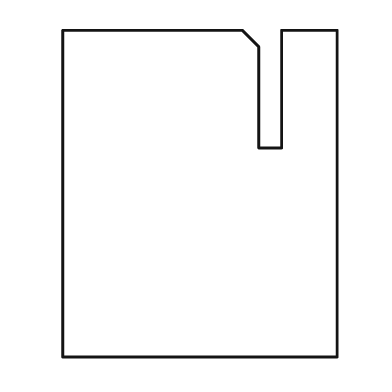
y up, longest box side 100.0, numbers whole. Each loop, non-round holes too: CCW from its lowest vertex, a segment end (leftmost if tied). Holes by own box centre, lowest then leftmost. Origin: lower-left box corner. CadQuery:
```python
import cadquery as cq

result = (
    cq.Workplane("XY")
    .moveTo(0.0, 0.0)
    .lineTo(84.0, 0.0)
    .lineTo(84.0, 100.0)
    .lineTo(67.0, 100.0)
    .lineTo(67.0, 64.0)
    .lineTo(60.0, 64.0)
    .lineTo(60.0, 95.0)
    .lineTo(55.0, 100.0)
    .lineTo(0.0, 100.0)
    .close()
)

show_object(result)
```